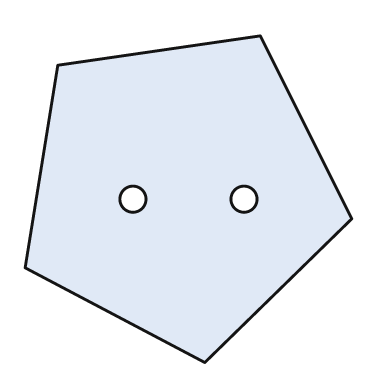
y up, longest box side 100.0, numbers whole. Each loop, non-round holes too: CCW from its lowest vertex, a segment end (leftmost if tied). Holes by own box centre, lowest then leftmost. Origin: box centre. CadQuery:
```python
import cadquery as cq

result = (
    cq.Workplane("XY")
    .moveTo(5.0, -50.0)
    .lineTo(50.0, -6.0)
    .lineTo(22.0, 50.0)
    .lineTo(-40.0, 41.0)
    .lineTo(-50.0, -21.0)
    .close()
    .moveTo(-17.0, 0.0)
    .circle(4.0)
    .moveTo(17.0, 0.0)
    .circle(4.0)
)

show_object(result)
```